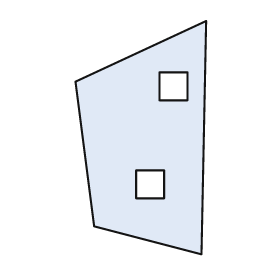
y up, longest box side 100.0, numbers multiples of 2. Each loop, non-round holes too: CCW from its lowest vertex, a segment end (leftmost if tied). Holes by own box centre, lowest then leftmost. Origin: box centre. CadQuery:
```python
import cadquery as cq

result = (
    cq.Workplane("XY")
    .moveTo(26.0, -50.0)
    .lineTo(28.0, 50.0)
    .lineTo(-28.0, 24.0)
    .lineTo(-20.0, -38.0)
    .close()
    .moveTo(-2.0, -26.0)
    .lineTo(10.0, -26.0)
    .lineTo(10.0, -14.0)
    .lineTo(-2.0, -14.0)
    .close()
    .moveTo(8.0, 16.0)
    .lineTo(20.0, 16.0)
    .lineTo(20.0, 28.0)
    .lineTo(8.0, 28.0)
    .close()
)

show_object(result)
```